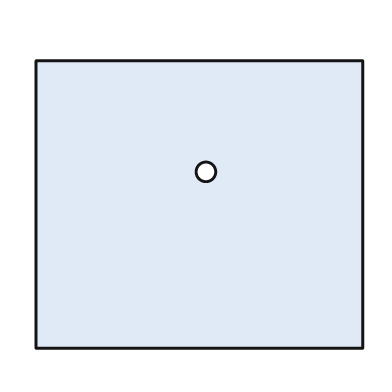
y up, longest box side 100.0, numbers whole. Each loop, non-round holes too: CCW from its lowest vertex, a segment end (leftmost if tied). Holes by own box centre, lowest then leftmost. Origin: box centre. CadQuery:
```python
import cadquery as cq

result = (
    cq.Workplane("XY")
    .moveTo(-50.0, -44.0)
    .lineTo(50.0, -44.0)
    .lineTo(50.0, 44.0)
    .lineTo(-50.0, 44.0)
    .close()
    .moveTo(2.0, 10.0)
    .circle(3.0)
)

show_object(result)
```